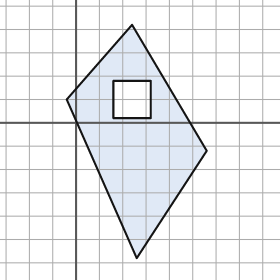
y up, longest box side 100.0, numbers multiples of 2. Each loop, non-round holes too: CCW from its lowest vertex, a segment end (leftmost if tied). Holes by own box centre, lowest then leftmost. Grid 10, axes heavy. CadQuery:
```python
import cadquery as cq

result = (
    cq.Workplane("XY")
    .moveTo(26.0, -58.0)
    .lineTo(56.0, -12.0)
    .lineTo(24.0, 42.0)
    .lineTo(-4.0, 10.0)
    .close()
    .moveTo(16.0, 2.0)
    .lineTo(32.0, 2.0)
    .lineTo(32.0, 18.0)
    .lineTo(16.0, 18.0)
    .close()
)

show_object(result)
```